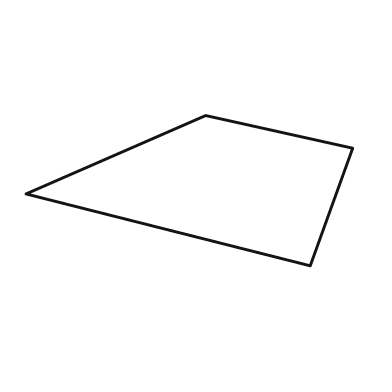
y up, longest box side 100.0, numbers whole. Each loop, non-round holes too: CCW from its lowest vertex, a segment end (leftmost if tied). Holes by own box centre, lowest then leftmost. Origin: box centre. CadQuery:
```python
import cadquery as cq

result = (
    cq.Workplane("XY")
    .moveTo(37.0, -23.0)
    .lineTo(50.0, 13.0)
    .lineTo(5.0, 23.0)
    .lineTo(-50.0, -1.0)
    .close()
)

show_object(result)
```